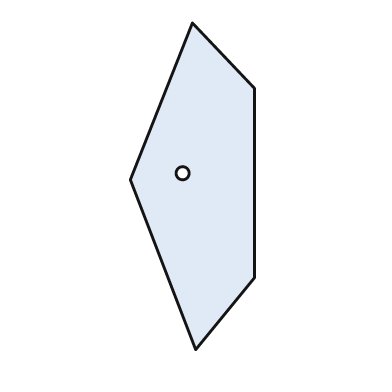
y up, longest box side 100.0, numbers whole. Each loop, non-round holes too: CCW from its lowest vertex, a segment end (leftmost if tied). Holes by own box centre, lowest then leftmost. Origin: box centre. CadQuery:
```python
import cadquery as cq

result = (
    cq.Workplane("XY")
    .moveTo(1.0, -50.0)
    .lineTo(19.0, -28.0)
    .lineTo(19.0, 30.0)
    .lineTo(0.0, 50.0)
    .lineTo(-19.0, 2.0)
    .close()
    .moveTo(-3.0, 4.0)
    .circle(2.0)
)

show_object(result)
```